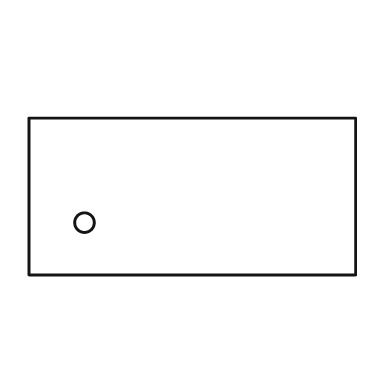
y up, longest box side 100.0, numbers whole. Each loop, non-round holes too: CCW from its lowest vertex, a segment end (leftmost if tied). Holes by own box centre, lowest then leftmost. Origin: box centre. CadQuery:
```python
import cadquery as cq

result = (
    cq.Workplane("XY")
    .moveTo(-50.0, -24.0)
    .lineTo(50.0, -24.0)
    .lineTo(50.0, 24.0)
    .lineTo(-50.0, 24.0)
    .close()
    .moveTo(-33.0, -8.0)
    .circle(3.0)
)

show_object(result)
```